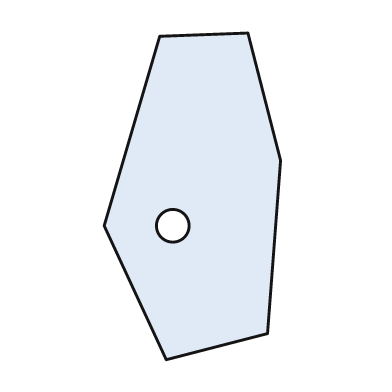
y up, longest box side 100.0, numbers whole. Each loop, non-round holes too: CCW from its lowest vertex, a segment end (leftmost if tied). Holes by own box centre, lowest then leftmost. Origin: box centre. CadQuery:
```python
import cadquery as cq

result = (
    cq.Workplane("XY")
    .moveTo(-8.0, -50.0)
    .lineTo(23.0, -42.0)
    .lineTo(27.0, 11.0)
    .lineTo(17.0, 50.0)
    .lineTo(-10.0, 49.0)
    .lineTo(-27.0, -9.0)
    .close()
    .moveTo(-6.0, -9.0)
    .circle(5.0)
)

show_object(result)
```